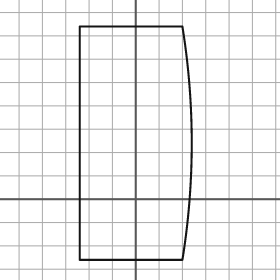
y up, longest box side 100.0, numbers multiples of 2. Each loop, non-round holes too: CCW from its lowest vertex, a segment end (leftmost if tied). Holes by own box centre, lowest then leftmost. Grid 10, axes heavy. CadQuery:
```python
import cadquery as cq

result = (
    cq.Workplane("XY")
    .moveTo(-24.0, -26.0)
    .lineTo(20.0, -26.0)
    .threePointArc((24.0, 24.0), (20.0, 74.0))
    .lineTo(-24.0, 74.0)
    .close()
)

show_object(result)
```